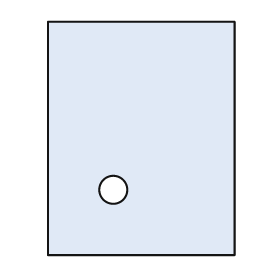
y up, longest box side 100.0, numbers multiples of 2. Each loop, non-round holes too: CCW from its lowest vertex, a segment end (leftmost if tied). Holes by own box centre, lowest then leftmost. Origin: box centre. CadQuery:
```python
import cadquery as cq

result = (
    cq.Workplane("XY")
    .moveTo(-40.0, -50.0)
    .lineTo(40.0, -50.0)
    .lineTo(40.0, 50.0)
    .lineTo(-40.0, 50.0)
    .close()
    .moveTo(-12.0, -22.0)
    .circle(6.0)
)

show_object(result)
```